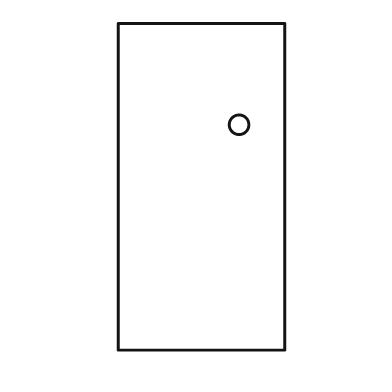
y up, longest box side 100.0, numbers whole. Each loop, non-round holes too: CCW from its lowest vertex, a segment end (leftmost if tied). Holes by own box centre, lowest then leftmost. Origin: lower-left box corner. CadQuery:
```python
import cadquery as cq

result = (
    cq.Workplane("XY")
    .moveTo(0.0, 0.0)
    .lineTo(51.0, 0.0)
    .lineTo(51.0, 100.0)
    .lineTo(0.0, 100.0)
    .close()
    .moveTo(37.0, 69.0)
    .circle(3.0)
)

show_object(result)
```